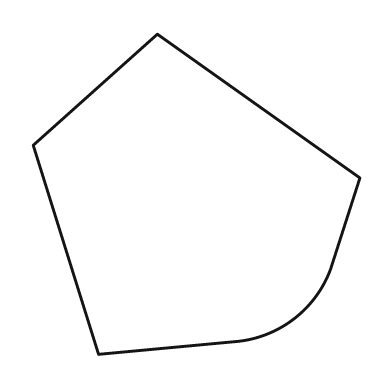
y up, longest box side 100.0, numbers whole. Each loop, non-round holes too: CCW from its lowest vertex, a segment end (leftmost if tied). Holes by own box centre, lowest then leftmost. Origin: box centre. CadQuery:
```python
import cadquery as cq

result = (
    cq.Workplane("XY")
    .moveTo(-30.0, -49.0)
    .lineTo(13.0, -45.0)
    .threePointArc((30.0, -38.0), (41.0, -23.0))
    .lineTo(50.0, 5.0)
    .lineTo(-12.0, 49.0)
    .lineTo(-50.0, 15.0)
    .close()
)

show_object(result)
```